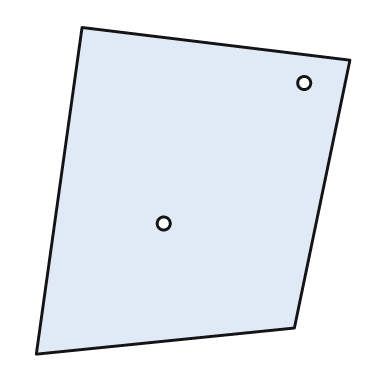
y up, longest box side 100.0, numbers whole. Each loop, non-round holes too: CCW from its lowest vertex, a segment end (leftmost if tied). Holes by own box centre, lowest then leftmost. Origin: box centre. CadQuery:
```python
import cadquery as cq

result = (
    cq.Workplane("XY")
    .moveTo(-48.0, -50.0)
    .lineTo(31.0, -42.0)
    .lineTo(48.0, 40.0)
    .lineTo(-34.0, 50.0)
    .close()
    .moveTo(-9.0, -10.0)
    .circle(2.0)
    .moveTo(34.0, 33.0)
    .circle(2.0)
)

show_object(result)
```